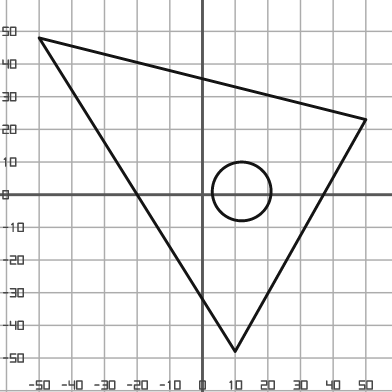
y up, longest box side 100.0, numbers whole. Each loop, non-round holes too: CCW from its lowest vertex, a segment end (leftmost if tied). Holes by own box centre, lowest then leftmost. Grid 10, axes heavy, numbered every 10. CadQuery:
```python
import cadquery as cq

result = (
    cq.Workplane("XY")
    .moveTo(10.0, -48.0)
    .lineTo(50.0, 23.0)
    .lineTo(-50.0, 48.0)
    .close()
    .moveTo(12.0, 1.0)
    .circle(9.0)
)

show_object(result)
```